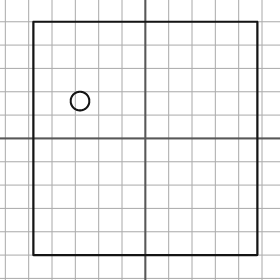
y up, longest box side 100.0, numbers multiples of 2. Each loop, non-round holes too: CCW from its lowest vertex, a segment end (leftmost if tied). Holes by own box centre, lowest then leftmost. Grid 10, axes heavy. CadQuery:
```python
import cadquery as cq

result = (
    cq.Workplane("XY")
    .moveTo(-48.0, -50.0)
    .lineTo(48.0, -50.0)
    .lineTo(48.0, 50.0)
    .lineTo(-48.0, 50.0)
    .close()
    .moveTo(-28.0, 16.0)
    .circle(4.0)
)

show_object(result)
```